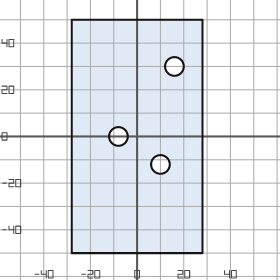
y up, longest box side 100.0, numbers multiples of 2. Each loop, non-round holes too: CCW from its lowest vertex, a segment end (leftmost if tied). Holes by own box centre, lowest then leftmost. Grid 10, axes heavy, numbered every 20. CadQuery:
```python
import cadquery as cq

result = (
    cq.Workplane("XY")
    .moveTo(-28.0, -50.0)
    .lineTo(28.0, -50.0)
    .lineTo(28.0, 50.0)
    .lineTo(-28.0, 50.0)
    .close()
    .moveTo(10.0, -12.0)
    .circle(4.0)
    .moveTo(-8.0, 0.0)
    .circle(4.0)
    .moveTo(16.0, 30.0)
    .circle(4.0)
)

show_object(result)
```